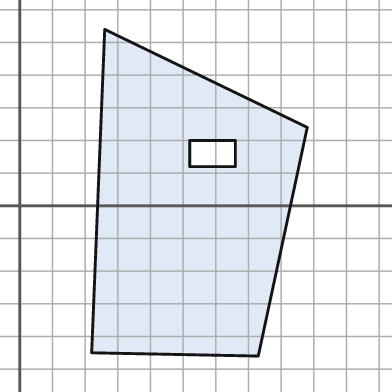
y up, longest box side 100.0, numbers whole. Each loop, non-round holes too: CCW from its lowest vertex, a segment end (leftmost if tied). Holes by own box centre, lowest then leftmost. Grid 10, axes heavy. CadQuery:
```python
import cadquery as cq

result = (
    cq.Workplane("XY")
    .moveTo(73.0, -46.0)
    .lineTo(88.0, 24.0)
    .lineTo(26.0, 54.0)
    .lineTo(22.0, -45.0)
    .close()
    .moveTo(52.0, 12.0)
    .lineTo(66.0, 12.0)
    .lineTo(66.0, 20.0)
    .lineTo(52.0, 20.0)
    .close()
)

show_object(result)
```